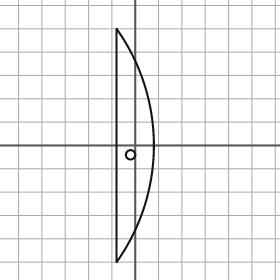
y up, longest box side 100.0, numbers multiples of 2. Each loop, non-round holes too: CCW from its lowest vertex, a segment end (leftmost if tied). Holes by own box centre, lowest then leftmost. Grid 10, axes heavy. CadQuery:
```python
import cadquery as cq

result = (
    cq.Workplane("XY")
    .moveTo(-8.0, -50.0)
    .threePointArc((8.0, 0.0), (-8.0, 50.0))
    .close()
    .moveTo(-2.0, -4.0)
    .circle(2.0)
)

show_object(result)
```